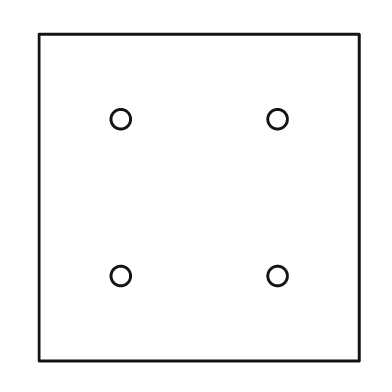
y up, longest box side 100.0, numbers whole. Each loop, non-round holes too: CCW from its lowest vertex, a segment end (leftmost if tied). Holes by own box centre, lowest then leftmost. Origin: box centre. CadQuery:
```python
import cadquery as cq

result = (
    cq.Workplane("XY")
    .moveTo(-49.0, -50.0)
    .lineTo(49.0, -50.0)
    .lineTo(49.0, 50.0)
    .lineTo(-49.0, 50.0)
    .close()
    .moveTo(-24.0, -24.0)
    .circle(3.0)
    .moveTo(24.0, -24.0)
    .circle(3.0)
    .moveTo(-24.0, 24.0)
    .circle(3.0)
    .moveTo(24.0, 24.0)
    .circle(3.0)
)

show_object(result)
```